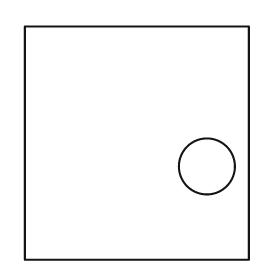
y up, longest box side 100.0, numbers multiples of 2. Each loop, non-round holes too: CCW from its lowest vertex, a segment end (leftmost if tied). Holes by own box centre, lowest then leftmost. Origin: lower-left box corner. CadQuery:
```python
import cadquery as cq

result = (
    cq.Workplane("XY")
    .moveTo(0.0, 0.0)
    .lineTo(96.0, 0.0)
    .lineTo(96.0, 100.0)
    .lineTo(0.0, 100.0)
    .close()
    .moveTo(78.0, 40.0)
    .circle(12.0)
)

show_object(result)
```